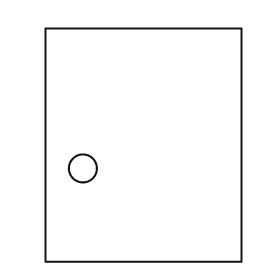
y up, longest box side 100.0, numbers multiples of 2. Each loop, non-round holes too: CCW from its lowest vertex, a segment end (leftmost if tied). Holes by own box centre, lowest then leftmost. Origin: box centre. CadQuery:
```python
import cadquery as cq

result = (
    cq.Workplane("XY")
    .moveTo(-42.0, -50.0)
    .lineTo(42.0, -50.0)
    .lineTo(42.0, 50.0)
    .lineTo(-42.0, 50.0)
    .close()
    .moveTo(-26.0, -10.0)
    .circle(6.0)
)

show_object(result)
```